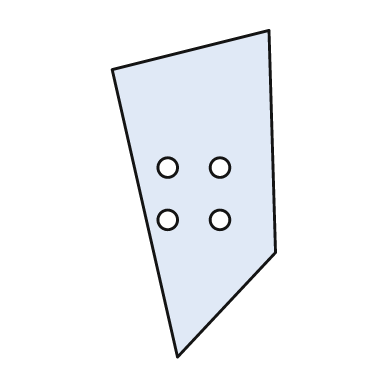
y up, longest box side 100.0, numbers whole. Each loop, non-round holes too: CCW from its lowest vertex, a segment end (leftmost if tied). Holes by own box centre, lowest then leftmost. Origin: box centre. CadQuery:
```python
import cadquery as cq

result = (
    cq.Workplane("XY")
    .moveTo(-5.0, -50.0)
    .lineTo(25.0, -18.0)
    .lineTo(23.0, 50.0)
    .lineTo(-25.0, 38.0)
    .close()
    .moveTo(-8.0, -8.0)
    .circle(3.0)
    .moveTo(8.0, -8.0)
    .circle(3.0)
    .moveTo(-8.0, 8.0)
    .circle(3.0)
    .moveTo(8.0, 8.0)
    .circle(3.0)
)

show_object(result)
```